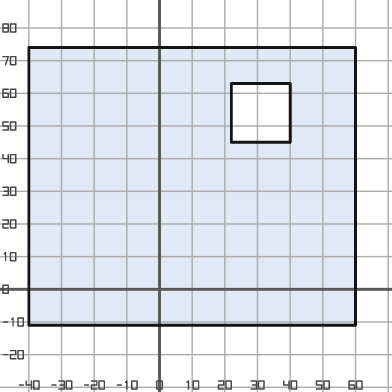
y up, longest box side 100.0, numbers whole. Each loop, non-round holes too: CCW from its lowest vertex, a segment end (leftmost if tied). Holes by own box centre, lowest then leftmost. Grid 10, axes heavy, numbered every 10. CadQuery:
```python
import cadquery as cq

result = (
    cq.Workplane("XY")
    .moveTo(-40.0, -11.0)
    .lineTo(60.0, -11.0)
    .lineTo(60.0, 74.0)
    .lineTo(-40.0, 74.0)
    .close()
    .moveTo(22.0, 45.0)
    .lineTo(40.0, 45.0)
    .lineTo(40.0, 63.0)
    .lineTo(22.0, 63.0)
    .close()
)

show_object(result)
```